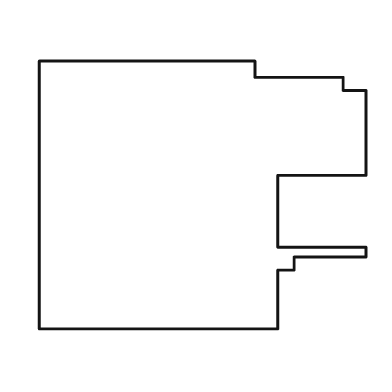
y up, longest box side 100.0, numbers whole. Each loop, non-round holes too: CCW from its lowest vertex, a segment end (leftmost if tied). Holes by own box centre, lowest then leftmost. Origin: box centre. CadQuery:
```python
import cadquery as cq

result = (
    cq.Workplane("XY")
    .moveTo(-50.0, -41.0)
    .lineTo(23.0, -41.0)
    .lineTo(23.0, -23.0)
    .lineTo(28.0, -23.0)
    .lineTo(28.0, -19.0)
    .lineTo(50.0, -19.0)
    .lineTo(50.0, -16.0)
    .lineTo(23.0, -16.0)
    .lineTo(23.0, 6.0)
    .lineTo(50.0, 6.0)
    .lineTo(50.0, 32.0)
    .lineTo(43.0, 32.0)
    .lineTo(43.0, 36.0)
    .lineTo(16.0, 36.0)
    .lineTo(16.0, 41.0)
    .lineTo(-50.0, 41.0)
    .close()
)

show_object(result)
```